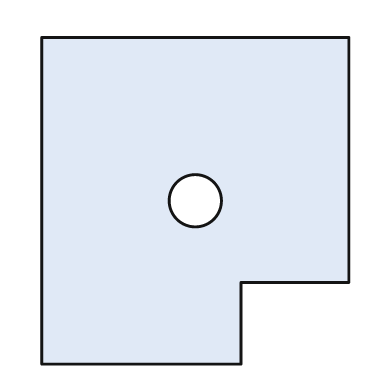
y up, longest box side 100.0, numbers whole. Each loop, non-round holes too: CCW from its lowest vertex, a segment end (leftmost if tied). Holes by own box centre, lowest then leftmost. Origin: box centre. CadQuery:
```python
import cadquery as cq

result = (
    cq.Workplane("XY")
    .moveTo(-47.0, -50.0)
    .lineTo(14.0, -50.0)
    .lineTo(14.0, -25.0)
    .lineTo(47.0, -25.0)
    .lineTo(47.0, 50.0)
    .lineTo(-47.0, 50.0)
    .close()
    .moveTo(0.0, 0.0)
    .circle(8.0)
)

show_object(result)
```